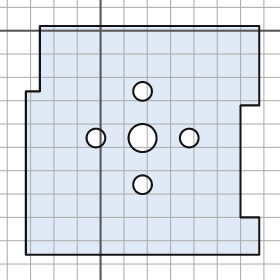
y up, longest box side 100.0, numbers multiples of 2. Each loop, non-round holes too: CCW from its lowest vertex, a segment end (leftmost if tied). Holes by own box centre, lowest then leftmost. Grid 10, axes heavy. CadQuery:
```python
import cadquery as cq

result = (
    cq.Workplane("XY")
    .moveTo(-32.0, -96.0)
    .lineTo(68.0, -96.0)
    .lineTo(68.0, -80.0)
    .lineTo(60.0, -80.0)
    .lineTo(60.0, -32.0)
    .lineTo(68.0, -32.0)
    .lineTo(68.0, 2.0)
    .lineTo(-26.0, 2.0)
    .lineTo(-26.0, -26.0)
    .lineTo(-32.0, -26.0)
    .close()
    .moveTo(18.0, -66.0)
    .circle(4.0)
    .moveTo(-2.0, -46.0)
    .circle(4.0)
    .moveTo(18.0, -46.0)
    .circle(6.0)
    .moveTo(38.0, -46.0)
    .circle(4.0)
    .moveTo(18.0, -26.0)
    .circle(4.0)
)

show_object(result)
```